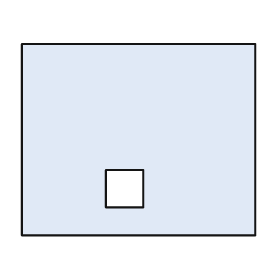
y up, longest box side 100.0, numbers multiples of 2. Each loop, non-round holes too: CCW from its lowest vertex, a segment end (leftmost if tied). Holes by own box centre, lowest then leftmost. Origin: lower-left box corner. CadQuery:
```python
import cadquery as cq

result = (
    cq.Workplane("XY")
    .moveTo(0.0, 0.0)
    .lineTo(100.0, 0.0)
    .lineTo(100.0, 82.0)
    .lineTo(0.0, 82.0)
    .close()
    .moveTo(36.0, 12.0)
    .lineTo(52.0, 12.0)
    .lineTo(52.0, 28.0)
    .lineTo(36.0, 28.0)
    .close()
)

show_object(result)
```